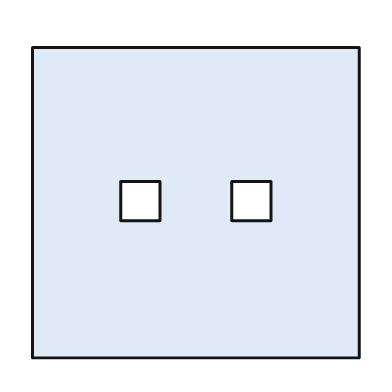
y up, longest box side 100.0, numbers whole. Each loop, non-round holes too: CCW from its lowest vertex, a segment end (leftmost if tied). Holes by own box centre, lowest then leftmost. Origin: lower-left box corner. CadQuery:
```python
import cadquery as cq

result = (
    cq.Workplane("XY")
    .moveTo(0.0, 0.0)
    .lineTo(100.0, 0.0)
    .lineTo(100.0, 95.0)
    .lineTo(0.0, 95.0)
    .close()
    .moveTo(27.0, 42.0)
    .lineTo(39.0, 42.0)
    .lineTo(39.0, 54.0)
    .lineTo(27.0, 54.0)
    .close()
    .moveTo(61.0, 42.0)
    .lineTo(73.0, 42.0)
    .lineTo(73.0, 54.0)
    .lineTo(61.0, 54.0)
    .close()
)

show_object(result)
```